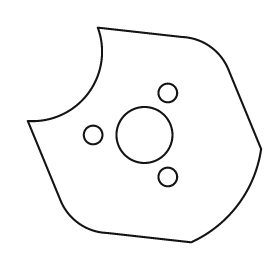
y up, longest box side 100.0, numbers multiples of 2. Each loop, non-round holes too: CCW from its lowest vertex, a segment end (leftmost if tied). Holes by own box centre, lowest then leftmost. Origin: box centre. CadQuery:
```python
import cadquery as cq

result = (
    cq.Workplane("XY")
    .moveTo(20.0, -46.0)
    .threePointArc((40.0, -30.0), (50.0, -6.0))
    .lineTo(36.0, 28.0)
    .threePointArc((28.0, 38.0), (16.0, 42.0))
    .lineTo(-20.0, 46.0)
    .threePointArc((-24.0, 18.0), (-50.0, 6.0))
    .lineTo(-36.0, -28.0)
    .threePointArc((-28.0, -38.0), (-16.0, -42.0))
    .close()
    .moveTo(10.0, -18.0)
    .circle(4.0)
    .moveTo(-22.0, 0.0)
    .circle(4.0)
    .moveTo(0.0, 0.0)
    .circle(12.0)
    .moveTo(10.0, 18.0)
    .circle(4.0)
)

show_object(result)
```